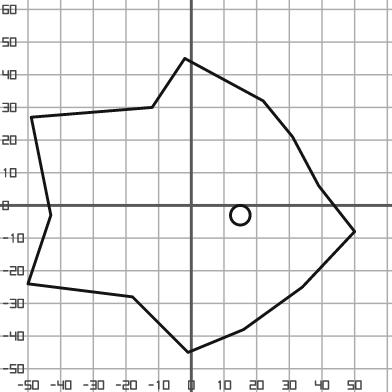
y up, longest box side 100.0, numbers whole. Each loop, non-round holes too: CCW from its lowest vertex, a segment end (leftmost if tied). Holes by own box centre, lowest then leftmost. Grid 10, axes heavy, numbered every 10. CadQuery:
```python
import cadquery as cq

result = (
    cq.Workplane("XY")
    .moveTo(-1.0, -45.0)
    .lineTo(16.0, -38.0)
    .lineTo(34.0, -25.0)
    .lineTo(50.0, -8.0)
    .lineTo(39.0, 6.0)
    .lineTo(31.0, 21.0)
    .lineTo(22.0, 32.0)
    .lineTo(-2.0, 45.0)
    .lineTo(-12.0, 30.0)
    .lineTo(-49.0, 27.0)
    .lineTo(-43.0, -3.0)
    .lineTo(-50.0, -24.0)
    .lineTo(-18.0, -28.0)
    .close()
    .moveTo(15.0, -3.0)
    .circle(3.0)
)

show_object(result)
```